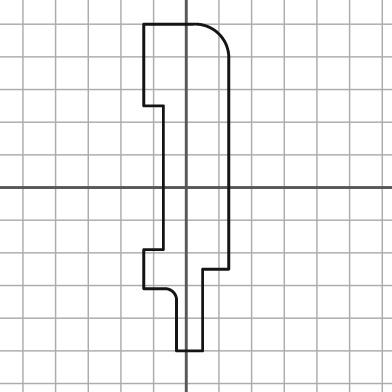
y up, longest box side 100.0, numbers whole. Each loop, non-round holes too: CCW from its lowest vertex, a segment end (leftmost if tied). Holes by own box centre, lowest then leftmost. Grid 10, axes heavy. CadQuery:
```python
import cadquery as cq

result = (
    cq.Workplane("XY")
    .moveTo(-3.0, -50.0)
    .lineTo(5.0, -50.0)
    .lineTo(5.0, -25.0)
    .lineTo(13.0, -25.0)
    .lineTo(13.0, 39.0)
    .threePointArc((10.0, 47.0), (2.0, 50.0))
    .lineTo(-13.0, 50.0)
    .lineTo(-13.0, 25.0)
    .lineTo(-7.0, 25.0)
    .lineTo(-7.0, -19.0)
    .lineTo(-13.0, -19.0)
    .lineTo(-13.0, -31.0)
    .lineTo(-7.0, -31.0)
    .threePointArc((-4.0, -32.0), (-3.0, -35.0))
    .close()
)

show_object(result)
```